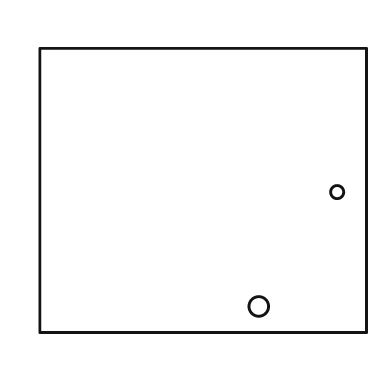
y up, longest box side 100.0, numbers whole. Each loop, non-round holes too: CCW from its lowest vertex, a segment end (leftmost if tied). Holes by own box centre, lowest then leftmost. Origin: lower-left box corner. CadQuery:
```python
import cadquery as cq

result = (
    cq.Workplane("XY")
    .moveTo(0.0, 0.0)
    .lineTo(100.0, 0.0)
    .lineTo(100.0, 87.0)
    .lineTo(0.0, 87.0)
    .close()
    .moveTo(67.0, 8.0)
    .circle(3.0)
    .moveTo(91.0, 43.0)
    .circle(2.0)
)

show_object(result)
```